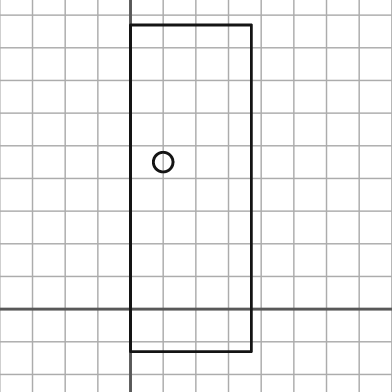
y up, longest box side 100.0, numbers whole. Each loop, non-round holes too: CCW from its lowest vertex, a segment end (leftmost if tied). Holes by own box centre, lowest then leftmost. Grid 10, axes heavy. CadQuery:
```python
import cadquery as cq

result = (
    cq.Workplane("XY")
    .moveTo(0.0, -13.0)
    .lineTo(37.0, -13.0)
    .lineTo(37.0, 87.0)
    .lineTo(0.0, 87.0)
    .close()
    .moveTo(10.0, 45.0)
    .circle(3.0)
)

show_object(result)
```